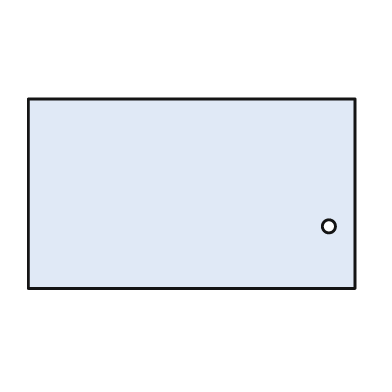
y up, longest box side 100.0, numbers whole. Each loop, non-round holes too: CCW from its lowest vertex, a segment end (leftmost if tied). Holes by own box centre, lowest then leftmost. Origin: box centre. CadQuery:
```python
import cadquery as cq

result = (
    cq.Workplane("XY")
    .moveTo(-50.0, -29.0)
    .lineTo(50.0, -29.0)
    .lineTo(50.0, 29.0)
    .lineTo(-50.0, 29.0)
    .close()
    .moveTo(42.0, -10.0)
    .circle(2.0)
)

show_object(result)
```